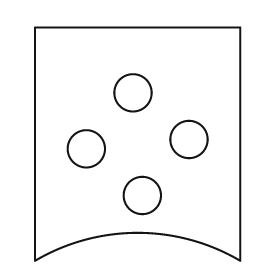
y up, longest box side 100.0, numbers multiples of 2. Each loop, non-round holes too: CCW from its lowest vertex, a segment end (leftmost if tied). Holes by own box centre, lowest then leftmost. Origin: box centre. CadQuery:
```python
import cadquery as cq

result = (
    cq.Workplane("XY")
    .moveTo(-44.0, -50.0)
    .threePointArc((0.0, -38.0), (44.0, -50.0))
    .lineTo(44.0, 50.0)
    .lineTo(-44.0, 50.0)
    .close()
    .moveTo(2.0, -22.0)
    .circle(8.0)
    .moveTo(-22.0, -2.0)
    .circle(8.0)
    .moveTo(22.0, 2.0)
    .circle(8.0)
    .moveTo(-2.0, 22.0)
    .circle(8.0)
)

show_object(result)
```